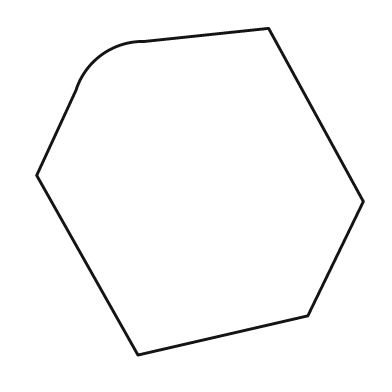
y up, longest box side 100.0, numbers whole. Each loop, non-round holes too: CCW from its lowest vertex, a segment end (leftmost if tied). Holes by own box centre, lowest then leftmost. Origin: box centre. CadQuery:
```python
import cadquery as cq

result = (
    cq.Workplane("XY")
    .moveTo(-19.0, -50.0)
    .lineTo(33.0, -38.0)
    .lineTo(50.0, -3.0)
    .lineTo(21.0, 50.0)
    .lineTo(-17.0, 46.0)
    .threePointArc((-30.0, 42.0), (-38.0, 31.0))
    .lineTo(-50.0, 5.0)
    .close()
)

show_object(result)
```